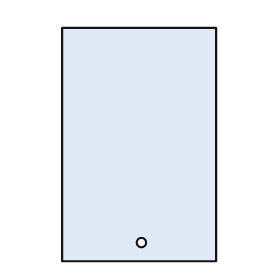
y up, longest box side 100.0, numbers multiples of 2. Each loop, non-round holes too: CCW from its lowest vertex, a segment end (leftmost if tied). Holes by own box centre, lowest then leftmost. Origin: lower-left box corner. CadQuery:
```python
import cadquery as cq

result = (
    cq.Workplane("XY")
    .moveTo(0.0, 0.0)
    .lineTo(66.0, 0.0)
    .lineTo(66.0, 100.0)
    .lineTo(0.0, 100.0)
    .close()
    .moveTo(34.0, 8.0)
    .circle(2.0)
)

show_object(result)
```